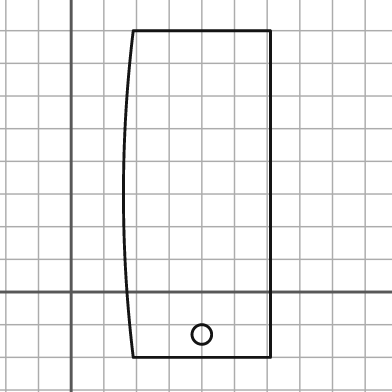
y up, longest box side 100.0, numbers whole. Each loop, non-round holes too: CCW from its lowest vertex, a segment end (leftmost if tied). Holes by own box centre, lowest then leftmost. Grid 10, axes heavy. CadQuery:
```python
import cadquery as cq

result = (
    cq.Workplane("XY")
    .moveTo(19.0, -20.0)
    .lineTo(61.0, -20.0)
    .lineTo(61.0, 80.0)
    .lineTo(19.0, 80.0)
    .threePointArc((16.0, 30.0), (19.0, -20.0))
    .close()
    .moveTo(40.0, -13.0)
    .circle(3.0)
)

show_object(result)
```